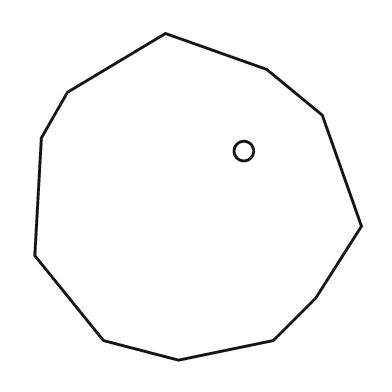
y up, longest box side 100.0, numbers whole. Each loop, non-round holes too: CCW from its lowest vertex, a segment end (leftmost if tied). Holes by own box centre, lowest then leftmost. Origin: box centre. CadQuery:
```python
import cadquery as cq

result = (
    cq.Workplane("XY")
    .moveTo(-6.0, -50.0)
    .lineTo(23.0, -44.0)
    .lineTo(36.0, -31.0)
    .lineTo(50.0, -9.0)
    .lineTo(38.0, 25.0)
    .lineTo(21.0, 39.0)
    .lineTo(-10.0, 50.0)
    .lineTo(-40.0, 32.0)
    .lineTo(-48.0, 18.0)
    .lineTo(-50.0, -18.0)
    .lineTo(-29.0, -44.0)
    .close()
    .moveTo(14.0, 14.0)
    .circle(3.0)
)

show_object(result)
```